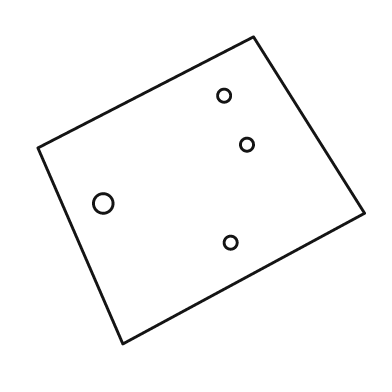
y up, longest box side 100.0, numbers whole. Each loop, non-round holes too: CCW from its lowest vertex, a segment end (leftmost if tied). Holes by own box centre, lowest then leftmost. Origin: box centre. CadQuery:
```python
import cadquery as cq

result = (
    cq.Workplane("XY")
    .moveTo(-24.0, -47.0)
    .lineTo(50.0, -7.0)
    .lineTo(16.0, 47.0)
    .lineTo(-50.0, 13.0)
    .close()
    .moveTo(9.0, -16.0)
    .circle(2.0)
    .moveTo(-30.0, -4.0)
    .circle(3.0)
    .moveTo(14.0, 14.0)
    .circle(2.0)
    .moveTo(7.0, 29.0)
    .circle(2.0)
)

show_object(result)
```